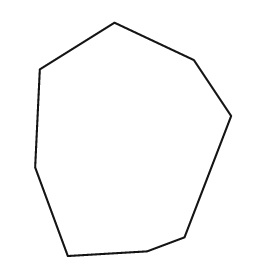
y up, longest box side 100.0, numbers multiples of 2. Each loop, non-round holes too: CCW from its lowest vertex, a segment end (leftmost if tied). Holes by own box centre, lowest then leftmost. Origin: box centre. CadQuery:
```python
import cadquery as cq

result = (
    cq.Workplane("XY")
    .moveTo(-28.0, -50.0)
    .lineTo(6.0, -48.0)
    .lineTo(22.0, -42.0)
    .lineTo(42.0, 10.0)
    .lineTo(26.0, 34.0)
    .lineTo(-8.0, 50.0)
    .lineTo(-40.0, 30.0)
    .lineTo(-42.0, -12.0)
    .close()
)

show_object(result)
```